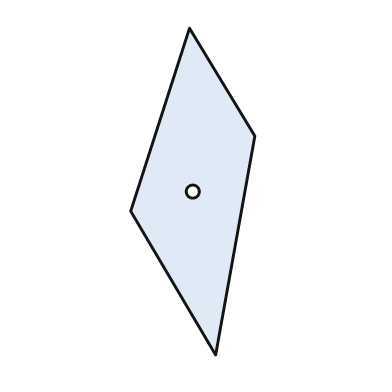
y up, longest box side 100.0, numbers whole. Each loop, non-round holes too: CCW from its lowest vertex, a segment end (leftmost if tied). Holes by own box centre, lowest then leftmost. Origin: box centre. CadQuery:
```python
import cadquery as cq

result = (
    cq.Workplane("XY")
    .moveTo(7.0, -50.0)
    .lineTo(19.0, 17.0)
    .lineTo(-1.0, 50.0)
    .lineTo(-19.0, -6.0)
    .close()
    .moveTo(0.0, 0.0)
    .circle(2.0)
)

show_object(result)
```